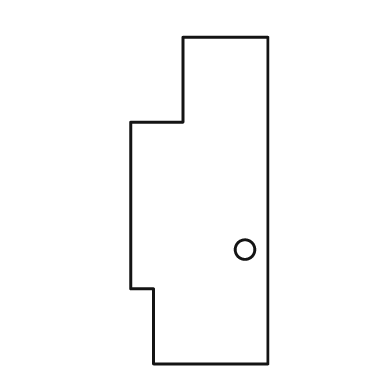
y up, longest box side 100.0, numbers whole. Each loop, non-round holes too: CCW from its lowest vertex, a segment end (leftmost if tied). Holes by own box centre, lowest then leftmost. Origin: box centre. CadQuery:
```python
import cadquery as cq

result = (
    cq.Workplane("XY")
    .moveTo(-14.0, -50.0)
    .lineTo(21.0, -50.0)
    .lineTo(21.0, 50.0)
    .lineTo(-5.0, 50.0)
    .lineTo(-5.0, 24.0)
    .lineTo(-21.0, 24.0)
    .lineTo(-21.0, -27.0)
    .lineTo(-14.0, -27.0)
    .close()
    .moveTo(14.0, -15.0)
    .circle(3.0)
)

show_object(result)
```